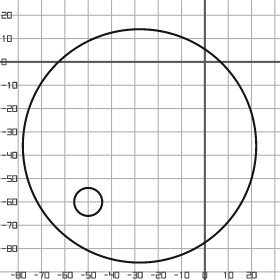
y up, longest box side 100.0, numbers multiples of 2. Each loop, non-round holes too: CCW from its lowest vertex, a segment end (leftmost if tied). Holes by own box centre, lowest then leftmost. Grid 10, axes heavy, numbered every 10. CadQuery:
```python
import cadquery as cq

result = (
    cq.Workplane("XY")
    .moveTo(-28.0, -36.0)
    .circle(50.0)
    .moveTo(-50.0, -60.0)
    .circle(6.0)
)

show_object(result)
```